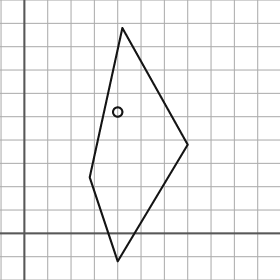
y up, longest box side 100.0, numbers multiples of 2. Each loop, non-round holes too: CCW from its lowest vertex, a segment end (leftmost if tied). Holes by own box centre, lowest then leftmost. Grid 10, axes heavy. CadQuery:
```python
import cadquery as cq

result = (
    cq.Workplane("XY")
    .moveTo(40.0, -12.0)
    .lineTo(70.0, 38.0)
    .lineTo(42.0, 88.0)
    .lineTo(28.0, 24.0)
    .close()
    .moveTo(40.0, 52.0)
    .circle(2.0)
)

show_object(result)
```